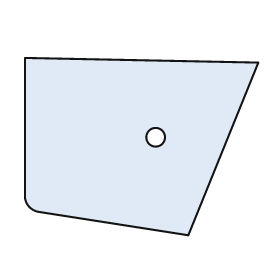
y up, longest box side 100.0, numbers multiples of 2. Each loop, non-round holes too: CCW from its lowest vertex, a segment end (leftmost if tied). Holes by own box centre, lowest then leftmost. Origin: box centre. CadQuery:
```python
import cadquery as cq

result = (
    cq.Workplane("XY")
    .moveTo(20.0, -38.0)
    .lineTo(50.0, 36.0)
    .lineTo(-50.0, 38.0)
    .lineTo(-50.0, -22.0)
    .threePointArc((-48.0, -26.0), (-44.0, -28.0))
    .close()
    .moveTo(6.0, 4.0)
    .circle(4.0)
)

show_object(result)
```